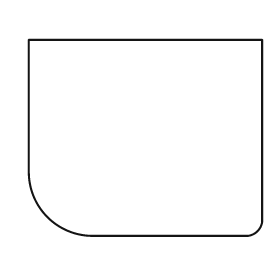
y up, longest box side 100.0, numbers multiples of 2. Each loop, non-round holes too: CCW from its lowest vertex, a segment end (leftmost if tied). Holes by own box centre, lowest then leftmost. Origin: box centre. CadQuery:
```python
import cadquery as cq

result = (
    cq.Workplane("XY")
    .moveTo(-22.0, -42.0)
    .lineTo(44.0, -42.0)
    .threePointArc((48.0, -40.0), (50.0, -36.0))
    .lineTo(50.0, 42.0)
    .lineTo(-50.0, 42.0)
    .lineTo(-50.0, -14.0)
    .threePointArc((-42.0, -34.0), (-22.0, -42.0))
    .close()
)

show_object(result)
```